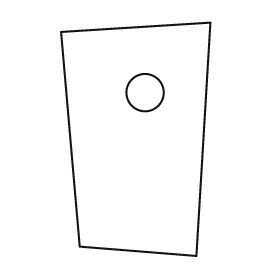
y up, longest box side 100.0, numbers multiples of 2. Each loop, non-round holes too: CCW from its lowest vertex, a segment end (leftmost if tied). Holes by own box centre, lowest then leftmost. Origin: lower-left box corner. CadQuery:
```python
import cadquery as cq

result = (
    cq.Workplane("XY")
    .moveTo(58.0, 0.0)
    .lineTo(64.0, 100.0)
    .lineTo(0.0, 96.0)
    .lineTo(8.0, 4.0)
    .close()
    .moveTo(36.0, 70.0)
    .circle(8.0)
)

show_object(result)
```